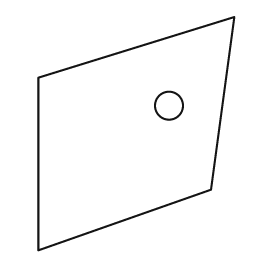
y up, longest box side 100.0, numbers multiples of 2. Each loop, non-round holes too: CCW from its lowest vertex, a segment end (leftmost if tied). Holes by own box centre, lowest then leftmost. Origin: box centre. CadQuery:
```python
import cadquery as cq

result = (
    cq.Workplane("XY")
    .moveTo(-42.0, -50.0)
    .lineTo(32.0, -24.0)
    .lineTo(42.0, 50.0)
    .lineTo(-42.0, 24.0)
    .close()
    .moveTo(14.0, 12.0)
    .circle(6.0)
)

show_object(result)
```